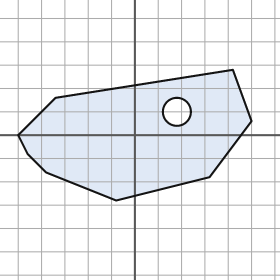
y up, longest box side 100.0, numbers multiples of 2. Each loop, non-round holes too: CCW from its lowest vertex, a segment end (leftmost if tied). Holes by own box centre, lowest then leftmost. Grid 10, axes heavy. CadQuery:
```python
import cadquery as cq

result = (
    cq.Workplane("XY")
    .moveTo(-8.0, -28.0)
    .lineTo(32.0, -18.0)
    .lineTo(50.0, 6.0)
    .lineTo(42.0, 28.0)
    .lineTo(-34.0, 16.0)
    .lineTo(-50.0, 0.0)
    .lineTo(-46.0, -8.0)
    .lineTo(-38.0, -16.0)
    .close()
    .moveTo(18.0, 10.0)
    .circle(6.0)
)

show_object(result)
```